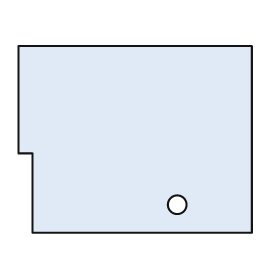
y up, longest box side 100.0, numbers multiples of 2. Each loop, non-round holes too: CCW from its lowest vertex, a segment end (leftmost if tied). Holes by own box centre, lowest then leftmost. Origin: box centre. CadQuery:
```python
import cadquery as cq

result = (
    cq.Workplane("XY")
    .moveTo(-44.0, -40.0)
    .lineTo(50.0, -40.0)
    .lineTo(50.0, 40.0)
    .lineTo(-50.0, 40.0)
    .lineTo(-50.0, -6.0)
    .lineTo(-44.0, -6.0)
    .close()
    .moveTo(18.0, -28.0)
    .circle(4.0)
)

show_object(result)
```